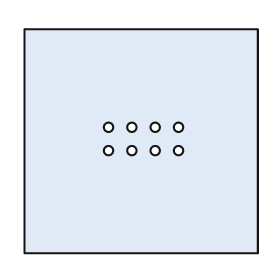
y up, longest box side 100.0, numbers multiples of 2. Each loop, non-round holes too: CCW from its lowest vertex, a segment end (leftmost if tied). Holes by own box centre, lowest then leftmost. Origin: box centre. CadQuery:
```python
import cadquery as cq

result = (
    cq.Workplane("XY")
    .moveTo(-50.0, -48.0)
    .lineTo(50.0, -48.0)
    .lineTo(50.0, 48.0)
    .lineTo(-50.0, 48.0)
    .close()
    .moveTo(-14.0, -4.0)
    .circle(2.0)
    .moveTo(-4.0, -4.0)
    .circle(2.0)
    .moveTo(6.0, -4.0)
    .circle(2.0)
    .moveTo(16.0, -4.0)
    .circle(2.0)
    .moveTo(-14.0, 6.0)
    .circle(2.0)
    .moveTo(-4.0, 6.0)
    .circle(2.0)
    .moveTo(6.0, 6.0)
    .circle(2.0)
    .moveTo(16.0, 6.0)
    .circle(2.0)
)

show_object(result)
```